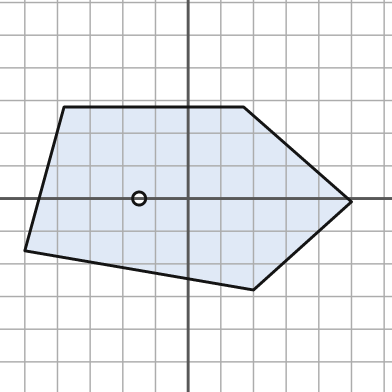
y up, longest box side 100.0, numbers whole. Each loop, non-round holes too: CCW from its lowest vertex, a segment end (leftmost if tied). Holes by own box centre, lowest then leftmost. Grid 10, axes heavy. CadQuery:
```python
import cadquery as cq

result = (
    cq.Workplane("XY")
    .moveTo(20.0, -28.0)
    .lineTo(50.0, -1.0)
    .lineTo(17.0, 28.0)
    .lineTo(-38.0, 28.0)
    .lineTo(-50.0, -16.0)
    .close()
    .moveTo(-15.0, 0.0)
    .circle(2.0)
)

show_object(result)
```